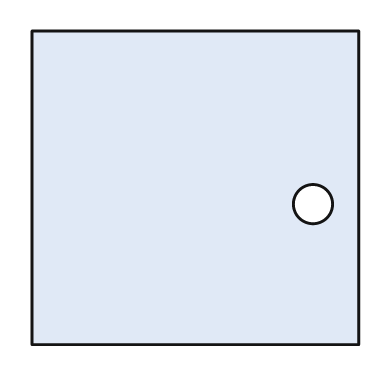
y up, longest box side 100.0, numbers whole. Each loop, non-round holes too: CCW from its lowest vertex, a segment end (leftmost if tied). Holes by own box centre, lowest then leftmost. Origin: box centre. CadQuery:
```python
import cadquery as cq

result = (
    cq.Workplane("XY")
    .moveTo(-50.0, -48.0)
    .lineTo(50.0, -48.0)
    .lineTo(50.0, 48.0)
    .lineTo(-50.0, 48.0)
    .close()
    .moveTo(36.0, -5.0)
    .circle(6.0)
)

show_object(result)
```